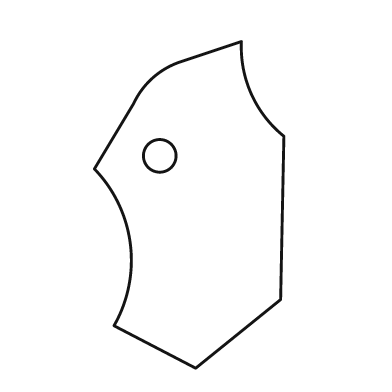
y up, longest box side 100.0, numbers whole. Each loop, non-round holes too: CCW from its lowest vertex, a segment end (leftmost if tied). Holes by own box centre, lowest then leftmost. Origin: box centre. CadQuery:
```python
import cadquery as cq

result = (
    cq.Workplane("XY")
    .moveTo(2.0, -50.0)
    .lineTo(28.0, -29.0)
    .lineTo(29.0, 21.0)
    .threePointArc((19.0, 34.0), (16.0, 50.0))
    .lineTo(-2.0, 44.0)
    .threePointArc((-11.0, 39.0), (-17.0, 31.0))
    .lineTo(-29.0, 11.0)
    .threePointArc((-18.0, -12.0), (-23.0, -37.0))
    .close()
    .moveTo(-9.0, 15.0)
    .circle(5.0)
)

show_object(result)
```